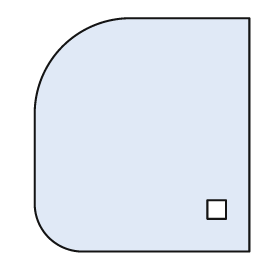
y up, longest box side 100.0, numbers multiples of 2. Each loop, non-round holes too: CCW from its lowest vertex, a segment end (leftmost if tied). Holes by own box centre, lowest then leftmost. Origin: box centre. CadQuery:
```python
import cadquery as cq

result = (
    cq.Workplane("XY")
    .moveTo(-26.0, -50.0)
    .lineTo(46.0, -50.0)
    .lineTo(46.0, 50.0)
    .lineTo(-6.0, 50.0)
    .threePointArc((-34.0, 38.0), (-46.0, 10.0))
    .lineTo(-46.0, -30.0)
    .threePointArc((-40.0, -44.0), (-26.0, -50.0))
    .close()
    .moveTo(28.0, -36.0)
    .lineTo(36.0, -36.0)
    .lineTo(36.0, -28.0)
    .lineTo(28.0, -28.0)
    .close()
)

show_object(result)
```